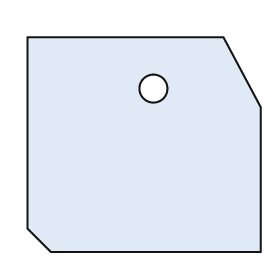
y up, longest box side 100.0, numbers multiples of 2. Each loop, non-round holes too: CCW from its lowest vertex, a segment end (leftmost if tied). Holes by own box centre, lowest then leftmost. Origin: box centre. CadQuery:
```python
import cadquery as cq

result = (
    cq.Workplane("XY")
    .moveTo(-40.0, -46.0)
    .lineTo(50.0, -46.0)
    .lineTo(50.0, 16.0)
    .lineTo(34.0, 46.0)
    .lineTo(-50.0, 46.0)
    .lineTo(-50.0, -36.0)
    .close()
    .moveTo(4.0, 24.0)
    .circle(6.0)
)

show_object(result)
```